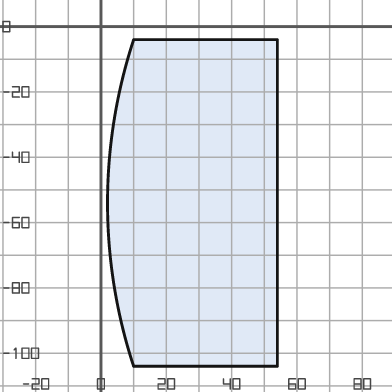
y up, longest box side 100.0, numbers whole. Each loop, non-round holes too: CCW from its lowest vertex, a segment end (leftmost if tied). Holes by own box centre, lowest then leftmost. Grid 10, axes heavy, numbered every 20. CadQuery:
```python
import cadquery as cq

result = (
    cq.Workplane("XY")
    .moveTo(10.0, -104.0)
    .lineTo(54.0, -104.0)
    .lineTo(54.0, -4.0)
    .lineTo(10.0, -4.0)
    .threePointArc((2.0, -54.0), (10.0, -104.0))
    .close()
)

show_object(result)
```